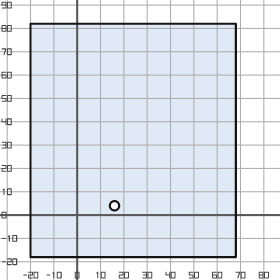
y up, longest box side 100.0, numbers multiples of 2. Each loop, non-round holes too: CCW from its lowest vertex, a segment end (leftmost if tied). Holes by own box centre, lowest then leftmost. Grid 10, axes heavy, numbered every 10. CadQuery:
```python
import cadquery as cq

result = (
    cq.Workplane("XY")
    .moveTo(-20.0, -18.0)
    .lineTo(68.0, -18.0)
    .lineTo(68.0, 82.0)
    .lineTo(-20.0, 82.0)
    .close()
    .moveTo(16.0, 4.0)
    .circle(2.0)
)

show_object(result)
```